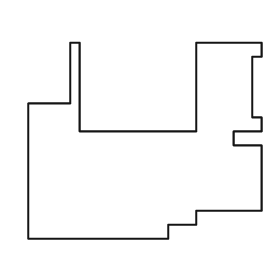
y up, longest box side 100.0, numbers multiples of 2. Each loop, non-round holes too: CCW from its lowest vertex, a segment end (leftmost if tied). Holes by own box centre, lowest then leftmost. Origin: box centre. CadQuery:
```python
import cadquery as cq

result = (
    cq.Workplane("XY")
    .moveTo(-50.0, -42.0)
    .lineTo(10.0, -42.0)
    .lineTo(10.0, -36.0)
    .lineTo(22.0, -36.0)
    .lineTo(22.0, -30.0)
    .lineTo(50.0, -30.0)
    .lineTo(50.0, -2.0)
    .lineTo(38.0, -2.0)
    .lineTo(38.0, 4.0)
    .lineTo(50.0, 4.0)
    .lineTo(50.0, 10.0)
    .lineTo(46.0, 10.0)
    .lineTo(46.0, 36.0)
    .lineTo(50.0, 36.0)
    .lineTo(50.0, 42.0)
    .lineTo(22.0, 42.0)
    .lineTo(22.0, 4.0)
    .lineTo(-28.0, 4.0)
    .lineTo(-28.0, 42.0)
    .lineTo(-32.0, 42.0)
    .lineTo(-32.0, 16.0)
    .lineTo(-50.0, 16.0)
    .close()
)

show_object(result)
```